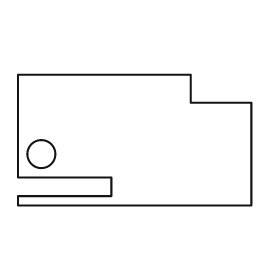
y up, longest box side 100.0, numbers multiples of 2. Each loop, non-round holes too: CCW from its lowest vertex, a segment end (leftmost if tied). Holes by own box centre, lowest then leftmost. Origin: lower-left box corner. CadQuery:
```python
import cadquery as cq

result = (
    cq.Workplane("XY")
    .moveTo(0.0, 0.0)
    .lineTo(100.0, 0.0)
    .lineTo(100.0, 44.0)
    .lineTo(74.0, 44.0)
    .lineTo(74.0, 56.0)
    .lineTo(0.0, 56.0)
    .lineTo(0.0, 12.0)
    .lineTo(40.0, 12.0)
    .lineTo(40.0, 4.0)
    .lineTo(0.0, 4.0)
    .close()
    .moveTo(10.0, 22.0)
    .circle(6.0)
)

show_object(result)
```